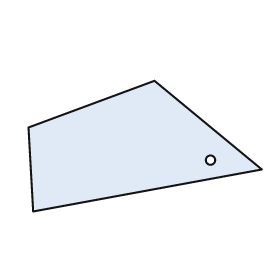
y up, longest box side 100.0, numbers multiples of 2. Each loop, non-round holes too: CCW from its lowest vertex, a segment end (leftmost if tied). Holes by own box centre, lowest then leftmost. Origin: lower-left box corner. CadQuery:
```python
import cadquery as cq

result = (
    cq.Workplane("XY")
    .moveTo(2.0, 0.0)
    .lineTo(100.0, 18.0)
    .lineTo(54.0, 56.0)
    .lineTo(0.0, 36.0)
    .close()
    .moveTo(78.0, 22.0)
    .circle(2.0)
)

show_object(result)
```